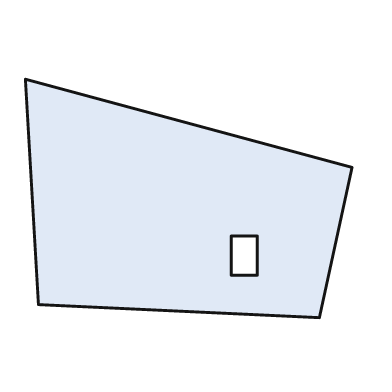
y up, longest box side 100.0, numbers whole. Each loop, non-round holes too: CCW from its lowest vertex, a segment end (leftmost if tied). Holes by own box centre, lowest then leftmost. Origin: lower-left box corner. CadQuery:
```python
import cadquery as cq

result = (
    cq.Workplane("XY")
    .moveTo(90.0, 0.0)
    .lineTo(100.0, 46.0)
    .lineTo(0.0, 73.0)
    .lineTo(4.0, 4.0)
    .close()
    .moveTo(63.0, 13.0)
    .lineTo(71.0, 13.0)
    .lineTo(71.0, 25.0)
    .lineTo(63.0, 25.0)
    .close()
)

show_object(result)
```